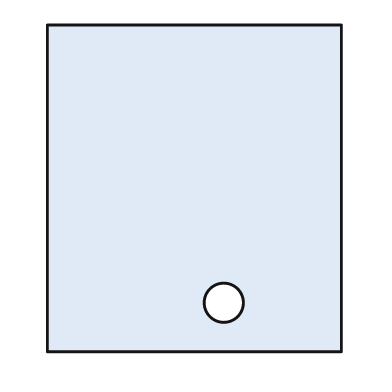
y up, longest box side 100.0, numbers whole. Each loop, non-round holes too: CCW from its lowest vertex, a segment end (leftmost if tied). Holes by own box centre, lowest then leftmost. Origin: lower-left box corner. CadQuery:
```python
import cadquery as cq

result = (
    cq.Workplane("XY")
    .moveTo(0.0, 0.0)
    .lineTo(90.0, 0.0)
    .lineTo(90.0, 100.0)
    .lineTo(0.0, 100.0)
    .close()
    .moveTo(54.0, 15.0)
    .circle(6.0)
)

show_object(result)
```